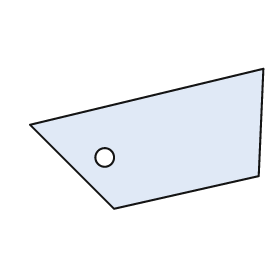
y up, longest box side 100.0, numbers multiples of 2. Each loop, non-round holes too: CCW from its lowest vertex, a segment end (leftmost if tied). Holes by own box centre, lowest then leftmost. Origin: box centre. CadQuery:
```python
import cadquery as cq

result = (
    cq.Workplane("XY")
    .moveTo(-14.0, -30.0)
    .lineTo(48.0, -16.0)
    .lineTo(50.0, 30.0)
    .lineTo(-50.0, 6.0)
    .close()
    .moveTo(-18.0, -8.0)
    .circle(4.0)
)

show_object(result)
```